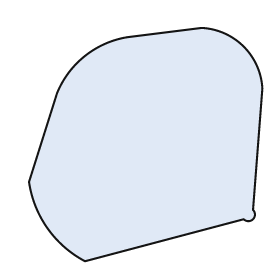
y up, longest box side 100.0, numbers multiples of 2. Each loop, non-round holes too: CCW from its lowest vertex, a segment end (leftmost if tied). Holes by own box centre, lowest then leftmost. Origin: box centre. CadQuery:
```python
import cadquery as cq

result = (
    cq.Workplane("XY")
    .moveTo(-26.0, -50.0)
    .lineTo(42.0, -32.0)
    .threePointArc((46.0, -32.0), (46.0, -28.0))
    .lineTo(50.0, 24.0)
    .threePointArc((42.0, 42.0), (24.0, 50.0))
    .lineTo(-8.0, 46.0)
    .threePointArc((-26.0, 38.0), (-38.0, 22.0))
    .lineTo(-50.0, -16.0)
    .threePointArc((-42.0, -36.0), (-26.0, -50.0))
    .close()
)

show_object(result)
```